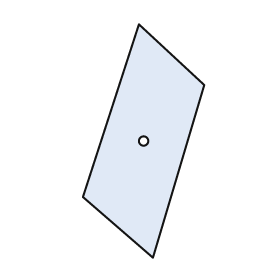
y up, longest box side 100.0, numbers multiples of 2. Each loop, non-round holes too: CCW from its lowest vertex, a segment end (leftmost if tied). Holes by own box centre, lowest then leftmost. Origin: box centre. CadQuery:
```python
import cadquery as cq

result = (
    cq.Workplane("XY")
    .moveTo(4.0, -50.0)
    .lineTo(26.0, 24.0)
    .lineTo(-2.0, 50.0)
    .lineTo(-26.0, -24.0)
    .close()
    .moveTo(0.0, 0.0)
    .circle(2.0)
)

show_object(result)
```